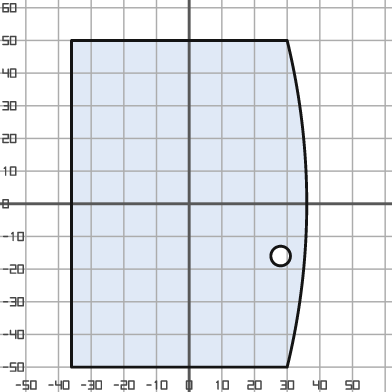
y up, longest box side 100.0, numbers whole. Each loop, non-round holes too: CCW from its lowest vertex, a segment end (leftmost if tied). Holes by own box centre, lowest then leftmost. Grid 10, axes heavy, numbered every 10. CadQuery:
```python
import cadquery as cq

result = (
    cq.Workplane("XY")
    .moveTo(-36.0, -50.0)
    .lineTo(30.0, -50.0)
    .threePointArc((36.0, 0.0), (30.0, 50.0))
    .lineTo(-36.0, 50.0)
    .close()
    .moveTo(28.0, -16.0)
    .circle(3.0)
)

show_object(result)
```